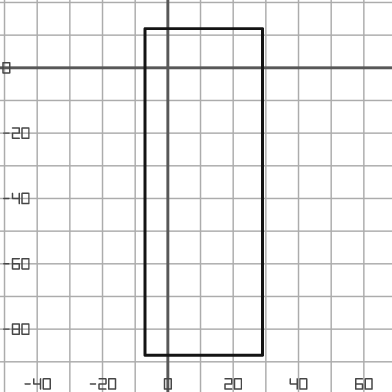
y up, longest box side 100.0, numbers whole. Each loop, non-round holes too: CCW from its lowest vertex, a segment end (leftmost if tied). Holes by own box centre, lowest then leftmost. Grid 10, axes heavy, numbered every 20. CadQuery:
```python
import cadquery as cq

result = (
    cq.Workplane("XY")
    .moveTo(-7.0, -88.0)
    .lineTo(29.0, -88.0)
    .lineTo(29.0, 12.0)
    .lineTo(-7.0, 12.0)
    .close()
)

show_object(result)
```